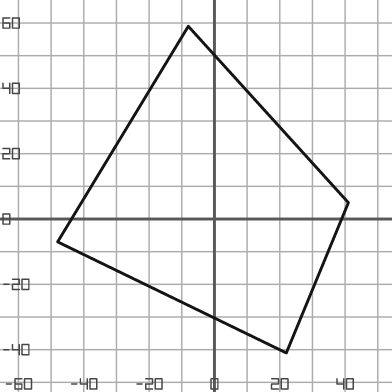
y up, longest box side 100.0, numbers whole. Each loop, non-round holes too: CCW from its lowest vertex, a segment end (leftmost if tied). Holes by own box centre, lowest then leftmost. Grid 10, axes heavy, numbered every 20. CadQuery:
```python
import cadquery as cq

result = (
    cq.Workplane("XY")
    .moveTo(22.0, -41.0)
    .lineTo(41.0, 5.0)
    .lineTo(-8.0, 59.0)
    .lineTo(-48.0, -7.0)
    .close()
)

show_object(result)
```